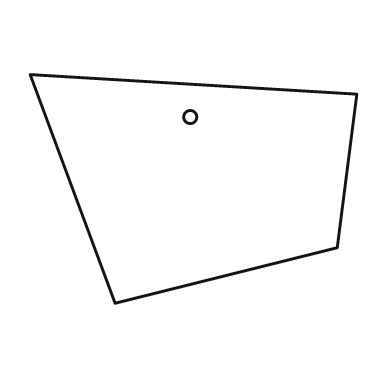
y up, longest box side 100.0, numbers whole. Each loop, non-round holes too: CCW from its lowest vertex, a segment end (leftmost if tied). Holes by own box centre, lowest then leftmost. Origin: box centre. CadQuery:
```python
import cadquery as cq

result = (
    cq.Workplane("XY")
    .moveTo(-24.0, -35.0)
    .lineTo(44.0, -18.0)
    .lineTo(50.0, 29.0)
    .lineTo(-50.0, 35.0)
    .close()
    .moveTo(-1.0, 22.0)
    .circle(2.0)
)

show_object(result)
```